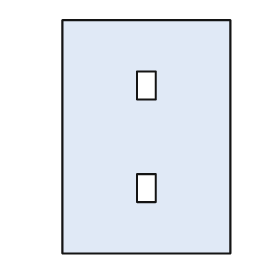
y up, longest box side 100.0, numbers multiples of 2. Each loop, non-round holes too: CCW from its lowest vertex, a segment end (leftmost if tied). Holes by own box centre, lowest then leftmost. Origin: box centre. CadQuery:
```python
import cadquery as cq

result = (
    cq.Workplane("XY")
    .moveTo(-36.0, -50.0)
    .lineTo(36.0, -50.0)
    .lineTo(36.0, 50.0)
    .lineTo(-36.0, 50.0)
    .close()
    .moveTo(-4.0, -28.0)
    .lineTo(4.0, -28.0)
    .lineTo(4.0, -16.0)
    .lineTo(-4.0, -16.0)
    .close()
    .moveTo(-4.0, 16.0)
    .lineTo(4.0, 16.0)
    .lineTo(4.0, 28.0)
    .lineTo(-4.0, 28.0)
    .close()
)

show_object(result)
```